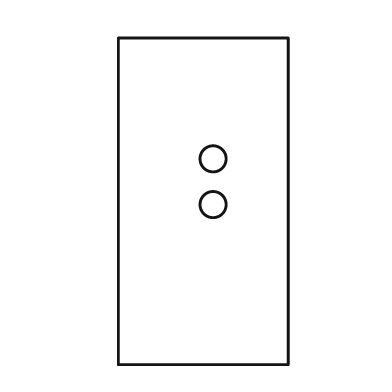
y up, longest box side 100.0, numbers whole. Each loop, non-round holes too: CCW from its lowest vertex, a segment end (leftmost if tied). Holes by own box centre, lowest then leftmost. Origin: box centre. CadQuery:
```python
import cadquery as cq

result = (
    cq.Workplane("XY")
    .moveTo(-26.0, -50.0)
    .lineTo(26.0, -50.0)
    .lineTo(26.0, 50.0)
    .lineTo(-26.0, 50.0)
    .close()
    .moveTo(3.0, -1.0)
    .circle(4.0)
    .moveTo(3.0, 13.0)
    .circle(4.0)
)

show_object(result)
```